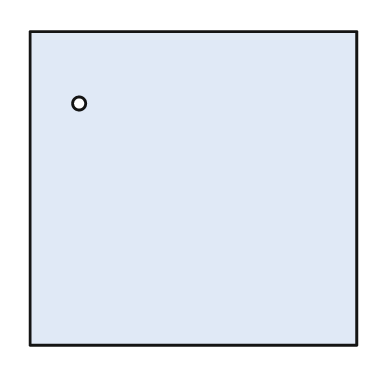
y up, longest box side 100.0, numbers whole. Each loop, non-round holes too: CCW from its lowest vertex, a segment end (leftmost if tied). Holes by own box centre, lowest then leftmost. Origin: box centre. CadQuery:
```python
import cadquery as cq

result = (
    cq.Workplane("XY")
    .moveTo(-50.0, -48.0)
    .lineTo(50.0, -48.0)
    .lineTo(50.0, 48.0)
    .lineTo(-50.0, 48.0)
    .close()
    .moveTo(-35.0, 26.0)
    .circle(2.0)
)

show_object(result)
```